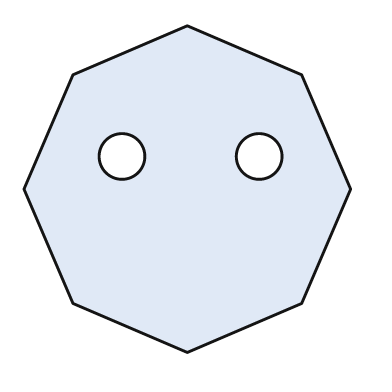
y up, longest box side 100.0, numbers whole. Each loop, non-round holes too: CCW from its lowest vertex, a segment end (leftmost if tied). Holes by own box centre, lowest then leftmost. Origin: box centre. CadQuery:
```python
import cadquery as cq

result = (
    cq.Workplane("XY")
    .moveTo(0.0, -50.0)
    .lineTo(35.0, -35.0)
    .lineTo(50.0, 0.0)
    .lineTo(35.0, 35.0)
    .lineTo(0.0, 50.0)
    .lineTo(-35.0, 35.0)
    .lineTo(-50.0, 0.0)
    .lineTo(-35.0, -35.0)
    .close()
    .moveTo(-20.0, 10.0)
    .circle(7.0)
    .moveTo(22.0, 10.0)
    .circle(7.0)
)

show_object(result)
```